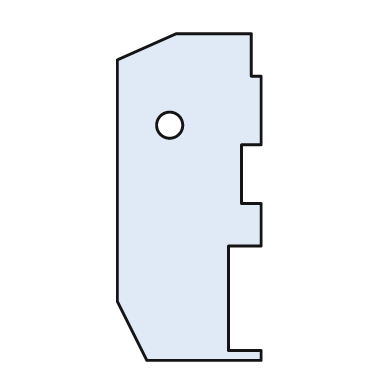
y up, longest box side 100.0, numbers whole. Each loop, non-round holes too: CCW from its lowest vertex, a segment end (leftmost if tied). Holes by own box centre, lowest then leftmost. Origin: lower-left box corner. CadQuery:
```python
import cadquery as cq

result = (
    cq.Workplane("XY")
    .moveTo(9.0, 0.0)
    .lineTo(44.0, 0.0)
    .lineTo(44.0, 3.0)
    .lineTo(34.0, 3.0)
    .lineTo(34.0, 35.0)
    .lineTo(44.0, 35.0)
    .lineTo(44.0, 48.0)
    .lineTo(38.0, 48.0)
    .lineTo(38.0, 66.0)
    .lineTo(44.0, 66.0)
    .lineTo(44.0, 87.0)
    .lineTo(41.0, 87.0)
    .lineTo(41.0, 100.0)
    .lineTo(18.0, 100.0)
    .lineTo(0.0, 92.0)
    .lineTo(0.0, 18.0)
    .close()
    .moveTo(16.0, 72.0)
    .circle(4.0)
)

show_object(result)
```